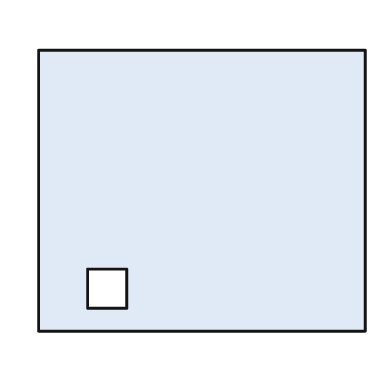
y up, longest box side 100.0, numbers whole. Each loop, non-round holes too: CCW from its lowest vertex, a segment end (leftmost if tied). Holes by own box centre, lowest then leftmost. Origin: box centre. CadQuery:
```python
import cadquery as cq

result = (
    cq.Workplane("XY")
    .moveTo(-50.0, -43.0)
    .lineTo(50.0, -43.0)
    .lineTo(50.0, 43.0)
    .lineTo(-50.0, 43.0)
    .close()
    .moveTo(-35.0, -36.0)
    .lineTo(-23.0, -36.0)
    .lineTo(-23.0, -24.0)
    .lineTo(-35.0, -24.0)
    .close()
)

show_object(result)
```